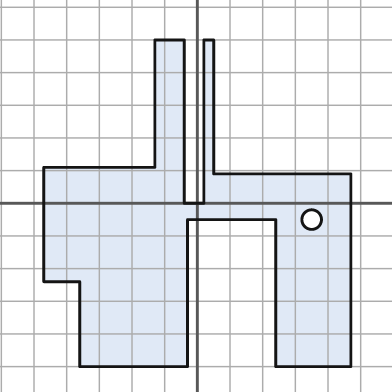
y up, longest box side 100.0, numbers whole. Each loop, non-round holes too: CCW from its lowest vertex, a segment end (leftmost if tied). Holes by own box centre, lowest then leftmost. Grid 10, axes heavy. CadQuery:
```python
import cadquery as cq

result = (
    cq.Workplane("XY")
    .moveTo(-36.0, -50.0)
    .lineTo(-3.0, -50.0)
    .lineTo(-3.0, -5.0)
    .lineTo(24.0, -5.0)
    .lineTo(24.0, -50.0)
    .lineTo(47.0, -50.0)
    .lineTo(47.0, 9.0)
    .lineTo(5.0, 9.0)
    .lineTo(5.0, 50.0)
    .lineTo(2.0, 50.0)
    .lineTo(2.0, 0.0)
    .lineTo(-4.0, 0.0)
    .lineTo(-4.0, 50.0)
    .lineTo(-13.0, 50.0)
    .lineTo(-13.0, 11.0)
    .lineTo(-47.0, 11.0)
    .lineTo(-47.0, -24.0)
    .lineTo(-36.0, -24.0)
    .close()
    .moveTo(35.0, -5.0)
    .circle(3.0)
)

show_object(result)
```